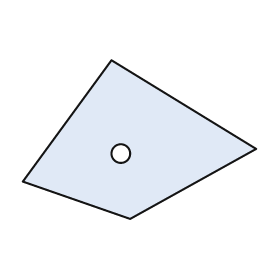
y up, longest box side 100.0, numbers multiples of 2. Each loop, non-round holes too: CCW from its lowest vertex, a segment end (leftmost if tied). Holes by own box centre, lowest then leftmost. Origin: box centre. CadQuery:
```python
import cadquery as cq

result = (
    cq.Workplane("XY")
    .moveTo(-4.0, -34.0)
    .lineTo(50.0, -4.0)
    .lineTo(-12.0, 34.0)
    .lineTo(-50.0, -18.0)
    .close()
    .moveTo(-8.0, -6.0)
    .circle(4.0)
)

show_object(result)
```